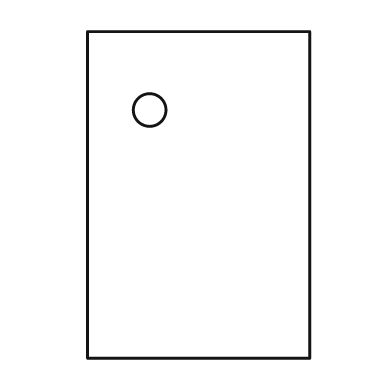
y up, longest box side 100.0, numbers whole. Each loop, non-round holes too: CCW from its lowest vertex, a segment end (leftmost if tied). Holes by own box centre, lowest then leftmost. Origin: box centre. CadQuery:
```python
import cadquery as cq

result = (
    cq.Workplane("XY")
    .moveTo(-34.0, -50.0)
    .lineTo(34.0, -50.0)
    .lineTo(34.0, 50.0)
    .lineTo(-34.0, 50.0)
    .close()
    .moveTo(-15.0, 26.0)
    .circle(5.0)
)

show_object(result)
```